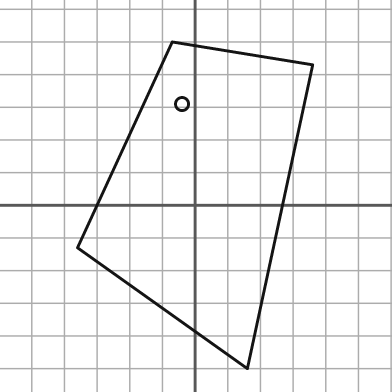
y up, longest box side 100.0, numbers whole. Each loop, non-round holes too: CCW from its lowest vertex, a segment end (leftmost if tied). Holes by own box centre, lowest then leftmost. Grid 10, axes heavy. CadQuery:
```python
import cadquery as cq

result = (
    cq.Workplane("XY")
    .moveTo(16.0, -50.0)
    .lineTo(36.0, 43.0)
    .lineTo(-7.0, 50.0)
    .lineTo(-36.0, -13.0)
    .close()
    .moveTo(-4.0, 31.0)
    .circle(2.0)
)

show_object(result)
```